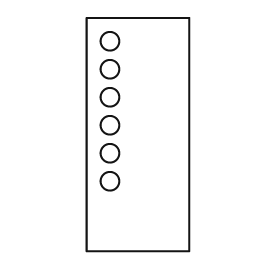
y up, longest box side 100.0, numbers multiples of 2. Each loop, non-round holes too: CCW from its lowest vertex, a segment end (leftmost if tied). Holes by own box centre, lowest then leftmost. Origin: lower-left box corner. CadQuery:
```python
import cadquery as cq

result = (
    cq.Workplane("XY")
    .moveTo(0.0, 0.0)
    .lineTo(44.0, 0.0)
    .lineTo(44.0, 100.0)
    .lineTo(0.0, 100.0)
    .close()
    .moveTo(10.0, 30.0)
    .circle(4.0)
    .moveTo(10.0, 42.0)
    .circle(4.0)
    .moveTo(10.0, 54.0)
    .circle(4.0)
    .moveTo(10.0, 66.0)
    .circle(4.0)
    .moveTo(10.0, 78.0)
    .circle(4.0)
    .moveTo(10.0, 90.0)
    .circle(4.0)
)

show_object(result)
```